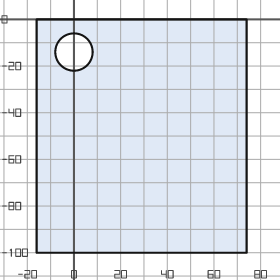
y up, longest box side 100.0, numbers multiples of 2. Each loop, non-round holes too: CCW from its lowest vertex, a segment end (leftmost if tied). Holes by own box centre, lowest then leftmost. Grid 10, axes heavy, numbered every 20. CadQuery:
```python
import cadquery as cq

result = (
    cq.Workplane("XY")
    .moveTo(-16.0, -100.0)
    .lineTo(74.0, -100.0)
    .lineTo(74.0, 0.0)
    .lineTo(-16.0, 0.0)
    .close()
    .moveTo(0.0, -14.0)
    .circle(8.0)
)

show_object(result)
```